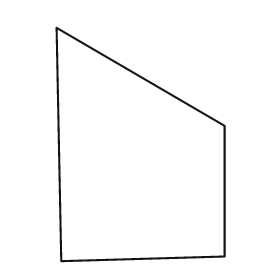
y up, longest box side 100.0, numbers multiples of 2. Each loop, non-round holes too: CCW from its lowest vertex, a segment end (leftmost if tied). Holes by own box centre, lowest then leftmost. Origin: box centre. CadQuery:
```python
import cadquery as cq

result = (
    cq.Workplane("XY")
    .moveTo(-34.0, -50.0)
    .lineTo(36.0, -48.0)
    .lineTo(36.0, 8.0)
    .lineTo(-36.0, 50.0)
    .close()
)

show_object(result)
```